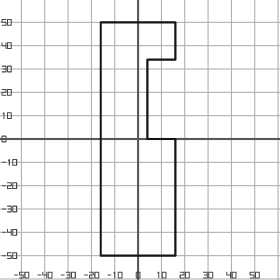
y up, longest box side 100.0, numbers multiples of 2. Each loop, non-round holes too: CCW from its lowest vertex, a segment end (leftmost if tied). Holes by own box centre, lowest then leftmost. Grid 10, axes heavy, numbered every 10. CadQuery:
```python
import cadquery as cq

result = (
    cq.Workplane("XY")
    .moveTo(-16.0, -50.0)
    .lineTo(16.0, -50.0)
    .lineTo(16.0, 0.0)
    .lineTo(4.0, 0.0)
    .lineTo(4.0, 34.0)
    .lineTo(16.0, 34.0)
    .lineTo(16.0, 50.0)
    .lineTo(-16.0, 50.0)
    .close()
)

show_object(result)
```